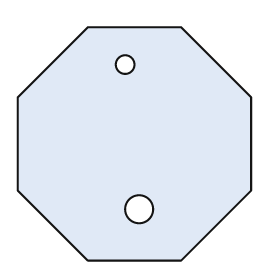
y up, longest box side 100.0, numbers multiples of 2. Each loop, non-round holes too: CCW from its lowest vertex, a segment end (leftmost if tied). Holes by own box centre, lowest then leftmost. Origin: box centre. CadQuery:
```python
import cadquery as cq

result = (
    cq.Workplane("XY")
    .moveTo(-20.0, -50.0)
    .lineTo(20.0, -50.0)
    .lineTo(50.0, -20.0)
    .lineTo(50.0, 20.0)
    .lineTo(20.0, 50.0)
    .lineTo(-20.0, 50.0)
    .lineTo(-50.0, 20.0)
    .lineTo(-50.0, -20.0)
    .close()
    .moveTo(2.0, -28.0)
    .circle(6.0)
    .moveTo(-4.0, 34.0)
    .circle(4.0)
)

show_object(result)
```